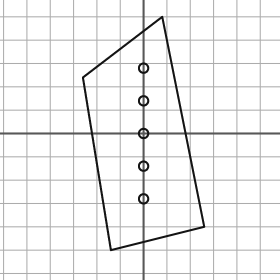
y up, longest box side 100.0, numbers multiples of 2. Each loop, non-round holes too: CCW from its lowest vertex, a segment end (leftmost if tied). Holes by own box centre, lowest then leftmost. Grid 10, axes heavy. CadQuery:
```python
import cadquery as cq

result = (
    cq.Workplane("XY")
    .moveTo(-14.0, -50.0)
    .lineTo(26.0, -40.0)
    .lineTo(8.0, 50.0)
    .lineTo(-26.0, 24.0)
    .close()
    .moveTo(0.0, -28.0)
    .circle(2.0)
    .moveTo(0.0, -14.0)
    .circle(2.0)
    .moveTo(0.0, 0.0)
    .circle(2.0)
    .moveTo(0.0, 14.0)
    .circle(2.0)
    .moveTo(0.0, 28.0)
    .circle(2.0)
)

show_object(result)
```